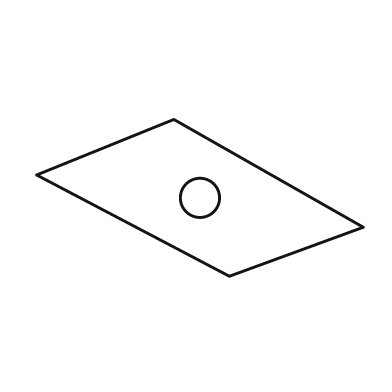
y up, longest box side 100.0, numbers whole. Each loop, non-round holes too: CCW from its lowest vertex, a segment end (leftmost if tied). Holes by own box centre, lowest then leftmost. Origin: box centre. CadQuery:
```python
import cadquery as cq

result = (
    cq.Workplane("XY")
    .moveTo(9.0, -24.0)
    .lineTo(50.0, -9.0)
    .lineTo(-8.0, 24.0)
    .lineTo(-50.0, 7.0)
    .close()
    .moveTo(0.0, 0.0)
    .circle(6.0)
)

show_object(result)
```